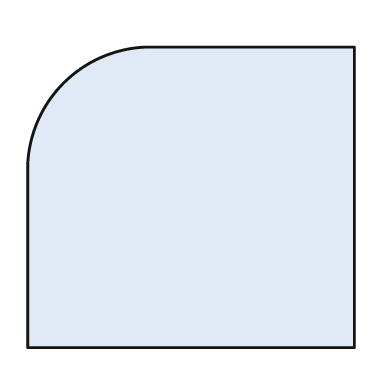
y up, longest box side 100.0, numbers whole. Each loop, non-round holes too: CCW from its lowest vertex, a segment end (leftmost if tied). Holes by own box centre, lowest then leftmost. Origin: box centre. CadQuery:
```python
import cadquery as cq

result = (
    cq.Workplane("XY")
    .moveTo(-50.0, -46.0)
    .lineTo(50.0, -46.0)
    .lineTo(50.0, 46.0)
    .lineTo(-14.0, 46.0)
    .threePointArc((-39.0, 35.0), (-50.0, 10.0))
    .close()
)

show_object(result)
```